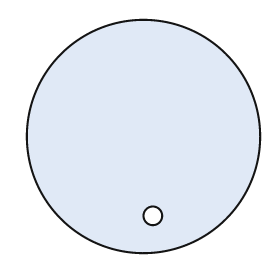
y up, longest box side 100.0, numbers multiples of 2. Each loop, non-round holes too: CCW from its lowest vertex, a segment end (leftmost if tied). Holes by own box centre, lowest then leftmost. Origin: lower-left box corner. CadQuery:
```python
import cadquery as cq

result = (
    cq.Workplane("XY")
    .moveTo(50.0, 50.0)
    .circle(50.0)
    .moveTo(54.0, 16.0)
    .circle(4.0)
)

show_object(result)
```